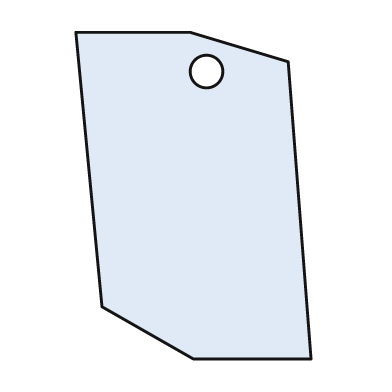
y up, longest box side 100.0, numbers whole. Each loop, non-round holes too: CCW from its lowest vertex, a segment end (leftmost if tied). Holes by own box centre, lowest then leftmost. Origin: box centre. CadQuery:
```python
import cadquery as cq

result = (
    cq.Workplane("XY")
    .moveTo(0.0, -50.0)
    .lineTo(36.0, -50.0)
    .lineTo(29.0, 41.0)
    .lineTo(-1.0, 50.0)
    .lineTo(-36.0, 50.0)
    .lineTo(-28.0, -34.0)
    .close()
    .moveTo(4.0, 38.0)
    .circle(5.0)
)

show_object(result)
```